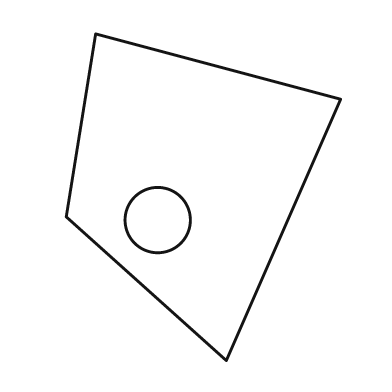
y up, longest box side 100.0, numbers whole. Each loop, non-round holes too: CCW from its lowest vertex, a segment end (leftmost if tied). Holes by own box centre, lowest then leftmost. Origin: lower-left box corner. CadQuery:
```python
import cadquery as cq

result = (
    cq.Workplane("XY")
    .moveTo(49.0, 0.0)
    .lineTo(84.0, 80.0)
    .lineTo(9.0, 100.0)
    .lineTo(0.0, 44.0)
    .close()
    .moveTo(28.0, 43.0)
    .circle(10.0)
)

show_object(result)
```